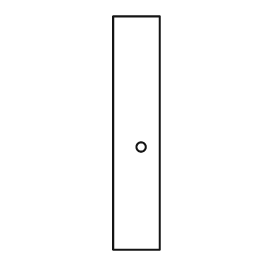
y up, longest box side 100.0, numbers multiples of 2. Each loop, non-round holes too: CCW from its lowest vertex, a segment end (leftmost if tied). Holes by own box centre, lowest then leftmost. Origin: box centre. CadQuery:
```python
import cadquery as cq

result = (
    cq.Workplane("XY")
    .moveTo(-10.0, -50.0)
    .lineTo(10.0, -50.0)
    .lineTo(10.0, 50.0)
    .lineTo(-10.0, 50.0)
    .close()
    .moveTo(2.0, -6.0)
    .circle(2.0)
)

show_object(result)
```